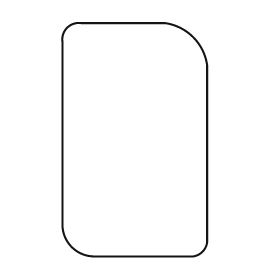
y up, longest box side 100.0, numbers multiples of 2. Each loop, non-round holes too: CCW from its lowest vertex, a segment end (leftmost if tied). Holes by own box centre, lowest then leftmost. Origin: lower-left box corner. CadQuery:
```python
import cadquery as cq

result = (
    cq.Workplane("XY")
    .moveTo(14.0, 0.0)
    .lineTo(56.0, 0.0)
    .threePointArc((60.0, 2.0), (62.0, 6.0))
    .lineTo(62.0, 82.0)
    .threePointArc((56.0, 94.0), (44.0, 100.0))
    .lineTo(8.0, 100.0)
    .threePointArc((2.0, 98.0), (0.0, 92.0))
    .lineTo(0.0, 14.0)
    .threePointArc((4.0, 4.0), (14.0, 0.0))
    .close()
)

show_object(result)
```